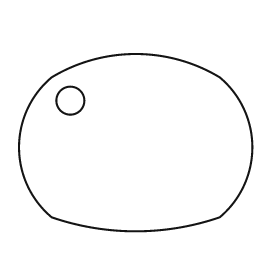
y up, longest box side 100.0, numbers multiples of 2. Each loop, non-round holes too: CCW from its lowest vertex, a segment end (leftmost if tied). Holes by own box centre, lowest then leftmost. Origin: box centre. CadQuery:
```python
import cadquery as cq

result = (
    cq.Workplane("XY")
    .moveTo(-36.0, -32.0)
    .threePointArc((0.0, -38.0), (36.0, -32.0))
    .threePointArc((50.0, -2.0), (36.0, 28.0))
    .threePointArc((0.0, 38.0), (-36.0, 28.0))
    .threePointArc((-50.0, -2.0), (-36.0, -32.0))
    .close()
    .moveTo(-28.0, 18.0)
    .circle(6.0)
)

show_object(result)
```